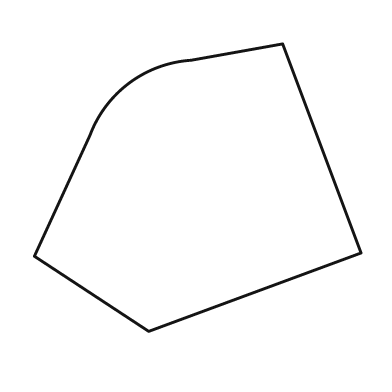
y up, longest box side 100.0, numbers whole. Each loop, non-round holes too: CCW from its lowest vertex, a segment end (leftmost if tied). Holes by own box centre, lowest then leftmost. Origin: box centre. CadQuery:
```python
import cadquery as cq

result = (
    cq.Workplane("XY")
    .moveTo(-15.0, -44.0)
    .lineTo(50.0, -20.0)
    .lineTo(26.0, 44.0)
    .lineTo(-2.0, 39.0)
    .threePointArc((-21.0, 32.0), (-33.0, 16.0))
    .lineTo(-50.0, -21.0)
    .close()
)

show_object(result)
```